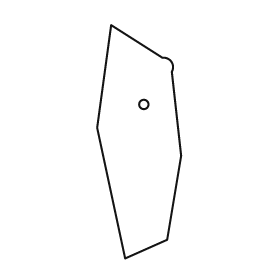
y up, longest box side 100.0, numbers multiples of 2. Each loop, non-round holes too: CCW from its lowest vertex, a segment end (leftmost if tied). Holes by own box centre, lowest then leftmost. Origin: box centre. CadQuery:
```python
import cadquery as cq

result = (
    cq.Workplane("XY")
    .moveTo(-6.0, -50.0)
    .lineTo(12.0, -42.0)
    .lineTo(18.0, -6.0)
    .lineTo(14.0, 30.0)
    .threePointArc((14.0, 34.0), (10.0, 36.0))
    .lineTo(-12.0, 50.0)
    .lineTo(-18.0, 6.0)
    .close()
    .moveTo(2.0, 16.0)
    .circle(2.0)
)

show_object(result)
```